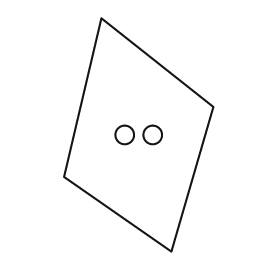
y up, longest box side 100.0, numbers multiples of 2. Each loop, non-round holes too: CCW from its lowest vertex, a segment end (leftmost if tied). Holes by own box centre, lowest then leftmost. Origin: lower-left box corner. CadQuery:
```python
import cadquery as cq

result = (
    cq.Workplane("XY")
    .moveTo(46.0, 0.0)
    .lineTo(64.0, 62.0)
    .lineTo(16.0, 100.0)
    .lineTo(0.0, 32.0)
    .close()
    .moveTo(26.0, 50.0)
    .circle(4.0)
    .moveTo(38.0, 50.0)
    .circle(4.0)
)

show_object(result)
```